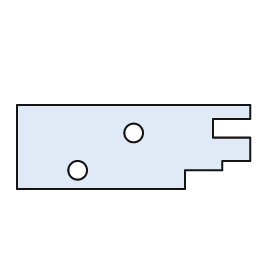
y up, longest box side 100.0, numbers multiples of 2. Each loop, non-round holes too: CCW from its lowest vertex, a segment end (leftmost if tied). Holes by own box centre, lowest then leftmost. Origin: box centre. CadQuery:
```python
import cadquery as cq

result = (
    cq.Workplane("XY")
    .moveTo(-50.0, -18.0)
    .lineTo(22.0, -18.0)
    .lineTo(22.0, -10.0)
    .lineTo(38.0, -10.0)
    .lineTo(38.0, -6.0)
    .lineTo(50.0, -6.0)
    .lineTo(50.0, 4.0)
    .lineTo(34.0, 4.0)
    .lineTo(34.0, 12.0)
    .lineTo(50.0, 12.0)
    .lineTo(50.0, 18.0)
    .lineTo(-50.0, 18.0)
    .close()
    .moveTo(-24.0, -10.0)
    .circle(4.0)
    .moveTo(0.0, 6.0)
    .circle(4.0)
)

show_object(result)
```